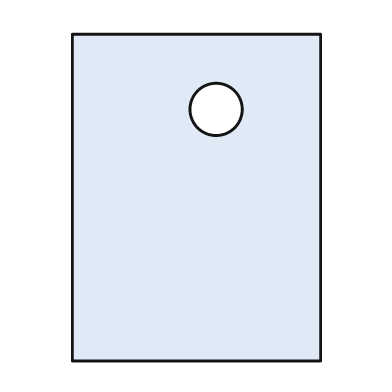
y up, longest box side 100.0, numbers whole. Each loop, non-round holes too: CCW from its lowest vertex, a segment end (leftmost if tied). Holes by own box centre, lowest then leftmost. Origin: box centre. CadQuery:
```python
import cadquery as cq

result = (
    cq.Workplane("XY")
    .moveTo(-38.0, -50.0)
    .lineTo(38.0, -50.0)
    .lineTo(38.0, 50.0)
    .lineTo(-38.0, 50.0)
    .close()
    .moveTo(6.0, 27.0)
    .circle(8.0)
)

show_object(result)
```